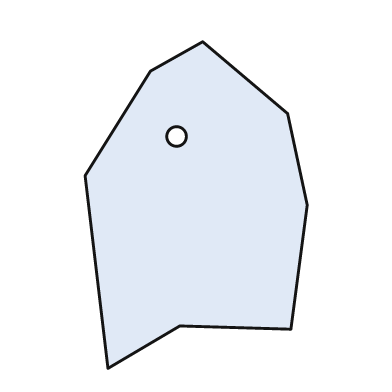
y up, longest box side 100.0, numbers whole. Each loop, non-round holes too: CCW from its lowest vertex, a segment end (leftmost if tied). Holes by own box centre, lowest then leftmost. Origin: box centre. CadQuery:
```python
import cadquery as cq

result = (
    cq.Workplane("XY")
    .moveTo(-27.0, -50.0)
    .lineTo(-5.0, -37.0)
    .lineTo(29.0, -38.0)
    .lineTo(34.0, 0.0)
    .lineTo(28.0, 28.0)
    .lineTo(2.0, 50.0)
    .lineTo(-14.0, 41.0)
    .lineTo(-34.0, 9.0)
    .close()
    .moveTo(-6.0, 21.0)
    .circle(3.0)
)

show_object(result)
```